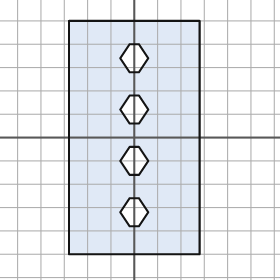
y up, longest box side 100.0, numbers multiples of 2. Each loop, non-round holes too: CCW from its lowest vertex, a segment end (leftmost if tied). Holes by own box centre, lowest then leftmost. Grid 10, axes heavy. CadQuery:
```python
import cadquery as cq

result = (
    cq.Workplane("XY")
    .moveTo(-28.0, -50.0)
    .lineTo(28.0, -50.0)
    .lineTo(28.0, 50.0)
    .lineTo(-28.0, 50.0)
    .close()
    .moveTo(-2.0, -38.0)
    .lineTo(2.0, -38.0)
    .lineTo(6.0, -32.0)
    .lineTo(2.0, -26.0)
    .lineTo(-2.0, -26.0)
    .lineTo(-6.0, -32.0)
    .close()
    .moveTo(-2.0, -16.0)
    .lineTo(2.0, -16.0)
    .lineTo(6.0, -10.0)
    .lineTo(2.0, -4.0)
    .lineTo(-2.0, -4.0)
    .lineTo(-6.0, -10.0)
    .close()
    .moveTo(-2.0, 6.0)
    .lineTo(2.0, 6.0)
    .lineTo(6.0, 12.0)
    .lineTo(2.0, 18.0)
    .lineTo(-2.0, 18.0)
    .lineTo(-6.0, 12.0)
    .close()
    .moveTo(-2.0, 28.0)
    .lineTo(2.0, 28.0)
    .lineTo(6.0, 34.0)
    .lineTo(2.0, 40.0)
    .lineTo(-2.0, 40.0)
    .lineTo(-6.0, 34.0)
    .close()
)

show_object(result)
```